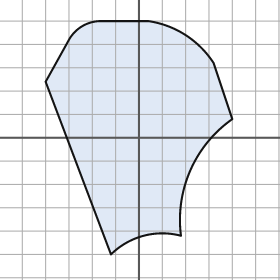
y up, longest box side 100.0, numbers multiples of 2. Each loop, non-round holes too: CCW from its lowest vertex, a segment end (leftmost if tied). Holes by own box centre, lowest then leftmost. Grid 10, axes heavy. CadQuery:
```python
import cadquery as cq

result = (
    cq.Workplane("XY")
    .moveTo(-12.0, -50.0)
    .threePointArc((2.0, -42.0), (18.0, -42.0))
    .threePointArc((22.0, -14.0), (40.0, 8.0))
    .lineTo(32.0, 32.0)
    .threePointArc((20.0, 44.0), (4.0, 50.0))
    .lineTo(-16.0, 50.0)
    .threePointArc((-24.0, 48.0), (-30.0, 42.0))
    .lineTo(-40.0, 24.0)
    .close()
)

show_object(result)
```